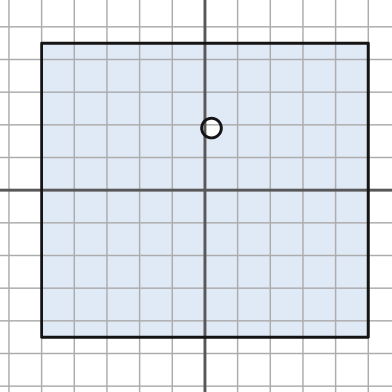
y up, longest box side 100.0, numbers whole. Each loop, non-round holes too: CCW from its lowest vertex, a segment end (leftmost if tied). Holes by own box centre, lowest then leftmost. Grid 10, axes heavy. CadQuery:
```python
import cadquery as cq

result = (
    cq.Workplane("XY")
    .moveTo(-50.0, -45.0)
    .lineTo(50.0, -45.0)
    .lineTo(50.0, 45.0)
    .lineTo(-50.0, 45.0)
    .close()
    .moveTo(2.0, 19.0)
    .circle(3.0)
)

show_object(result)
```